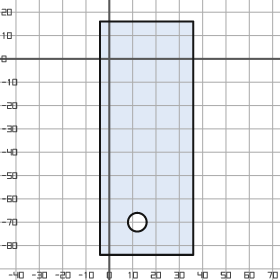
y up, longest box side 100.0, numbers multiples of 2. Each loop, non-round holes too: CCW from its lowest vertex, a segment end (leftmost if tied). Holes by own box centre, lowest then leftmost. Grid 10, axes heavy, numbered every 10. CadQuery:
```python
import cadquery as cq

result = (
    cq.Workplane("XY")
    .moveTo(-4.0, -84.0)
    .lineTo(36.0, -84.0)
    .lineTo(36.0, 16.0)
    .lineTo(-4.0, 16.0)
    .close()
    .moveTo(12.0, -70.0)
    .circle(4.0)
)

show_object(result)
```